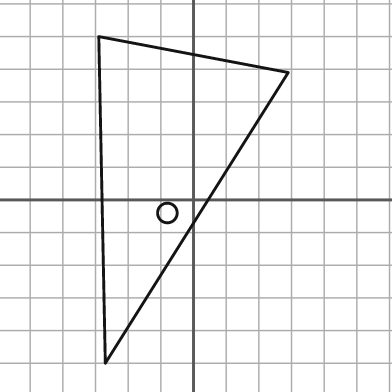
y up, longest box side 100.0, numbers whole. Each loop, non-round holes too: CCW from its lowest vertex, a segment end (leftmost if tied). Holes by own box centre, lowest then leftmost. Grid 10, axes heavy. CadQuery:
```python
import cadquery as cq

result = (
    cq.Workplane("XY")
    .moveTo(-27.0, -50.0)
    .lineTo(29.0, 39.0)
    .lineTo(-29.0, 50.0)
    .close()
    .moveTo(-8.0, -4.0)
    .circle(3.0)
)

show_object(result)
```